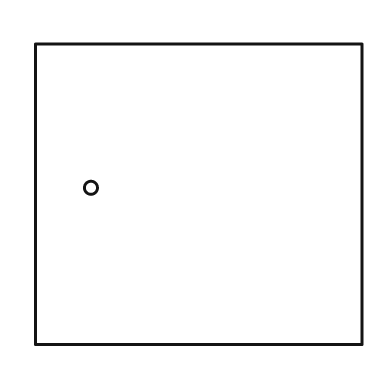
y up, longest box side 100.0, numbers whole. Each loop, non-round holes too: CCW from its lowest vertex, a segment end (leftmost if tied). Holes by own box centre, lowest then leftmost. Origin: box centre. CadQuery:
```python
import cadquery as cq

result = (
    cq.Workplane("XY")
    .moveTo(-50.0, -46.0)
    .lineTo(50.0, -46.0)
    .lineTo(50.0, 46.0)
    .lineTo(-50.0, 46.0)
    .close()
    .moveTo(-33.0, 2.0)
    .circle(2.0)
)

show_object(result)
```